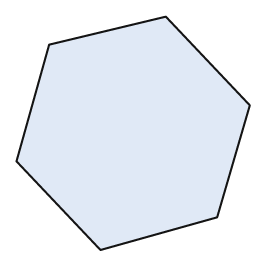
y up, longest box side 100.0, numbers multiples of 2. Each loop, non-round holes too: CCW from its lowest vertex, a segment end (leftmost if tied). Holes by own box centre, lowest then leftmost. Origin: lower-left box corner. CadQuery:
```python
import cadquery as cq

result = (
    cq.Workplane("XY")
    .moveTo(36.0, 0.0)
    .lineTo(86.0, 14.0)
    .lineTo(100.0, 62.0)
    .lineTo(64.0, 100.0)
    .lineTo(14.0, 88.0)
    .lineTo(0.0, 38.0)
    .close()
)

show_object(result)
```